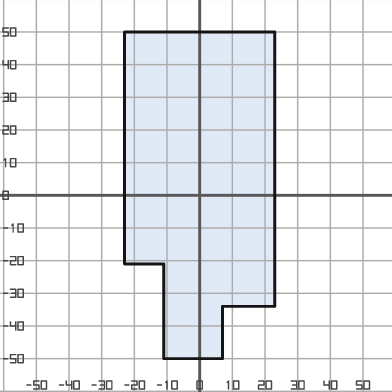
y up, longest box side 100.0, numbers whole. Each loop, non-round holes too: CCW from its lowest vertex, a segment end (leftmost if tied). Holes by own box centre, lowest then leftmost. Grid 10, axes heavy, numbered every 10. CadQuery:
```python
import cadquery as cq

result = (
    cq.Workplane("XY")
    .moveTo(-11.0, -50.0)
    .lineTo(7.0, -50.0)
    .lineTo(7.0, -34.0)
    .lineTo(23.0, -34.0)
    .lineTo(23.0, 50.0)
    .lineTo(-23.0, 50.0)
    .lineTo(-23.0, -21.0)
    .lineTo(-11.0, -21.0)
    .close()
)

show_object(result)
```